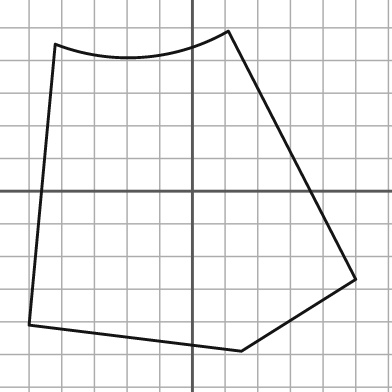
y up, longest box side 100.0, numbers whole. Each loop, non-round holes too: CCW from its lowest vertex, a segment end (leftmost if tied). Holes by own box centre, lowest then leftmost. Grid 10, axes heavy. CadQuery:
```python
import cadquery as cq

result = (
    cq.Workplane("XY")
    .moveTo(15.0, -49.0)
    .lineTo(50.0, -27.0)
    .lineTo(11.0, 49.0)
    .threePointArc((-15.0, 41.0), (-42.0, 45.0))
    .lineTo(-50.0, -41.0)
    .close()
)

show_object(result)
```